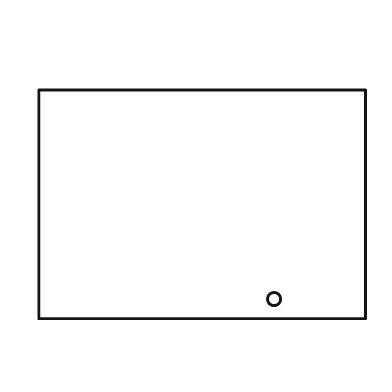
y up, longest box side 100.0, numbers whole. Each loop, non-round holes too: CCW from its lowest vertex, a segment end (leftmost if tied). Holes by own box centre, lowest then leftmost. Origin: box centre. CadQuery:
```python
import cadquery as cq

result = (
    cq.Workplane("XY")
    .moveTo(-50.0, -35.0)
    .lineTo(50.0, -35.0)
    .lineTo(50.0, 35.0)
    .lineTo(-50.0, 35.0)
    .close()
    .moveTo(22.0, -29.0)
    .circle(2.0)
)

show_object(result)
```